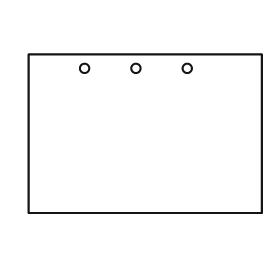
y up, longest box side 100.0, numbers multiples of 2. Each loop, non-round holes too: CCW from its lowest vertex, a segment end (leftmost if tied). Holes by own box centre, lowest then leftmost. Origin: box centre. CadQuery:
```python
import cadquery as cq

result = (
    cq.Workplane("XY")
    .moveTo(-50.0, -34.0)
    .lineTo(50.0, -34.0)
    .lineTo(50.0, 34.0)
    .lineTo(-50.0, 34.0)
    .close()
    .moveTo(-26.0, 28.0)
    .circle(2.0)
    .moveTo(-4.0, 28.0)
    .circle(2.0)
    .moveTo(18.0, 28.0)
    .circle(2.0)
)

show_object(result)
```